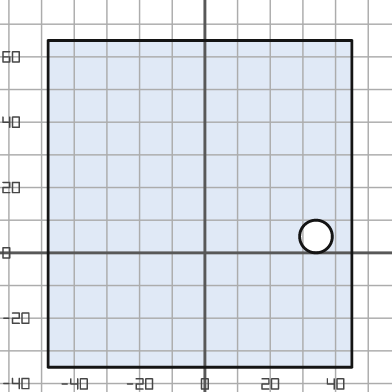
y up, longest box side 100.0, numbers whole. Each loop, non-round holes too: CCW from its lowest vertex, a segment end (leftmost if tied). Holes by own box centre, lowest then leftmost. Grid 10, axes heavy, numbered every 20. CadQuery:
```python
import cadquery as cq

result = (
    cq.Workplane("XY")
    .moveTo(-48.0, -35.0)
    .lineTo(45.0, -35.0)
    .lineTo(45.0, 65.0)
    .lineTo(-48.0, 65.0)
    .close()
    .moveTo(34.0, 5.0)
    .circle(5.0)
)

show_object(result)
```